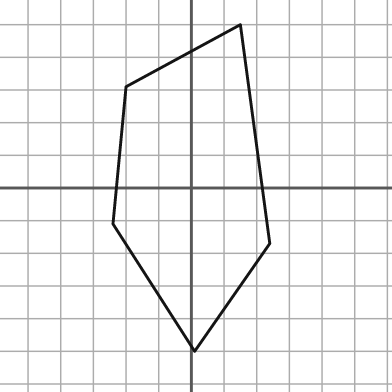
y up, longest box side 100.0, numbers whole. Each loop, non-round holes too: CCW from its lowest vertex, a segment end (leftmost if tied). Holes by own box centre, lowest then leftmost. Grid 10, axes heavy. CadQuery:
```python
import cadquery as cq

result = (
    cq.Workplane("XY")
    .moveTo(1.0, -50.0)
    .lineTo(24.0, -17.0)
    .lineTo(15.0, 50.0)
    .lineTo(-20.0, 31.0)
    .lineTo(-24.0, -11.0)
    .close()
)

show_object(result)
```